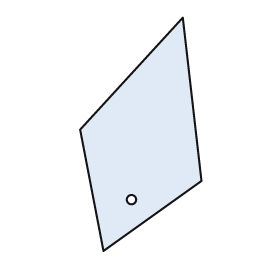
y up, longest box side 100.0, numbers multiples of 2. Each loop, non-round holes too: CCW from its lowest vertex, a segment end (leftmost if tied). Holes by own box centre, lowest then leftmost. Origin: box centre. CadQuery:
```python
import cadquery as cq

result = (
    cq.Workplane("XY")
    .moveTo(-16.0, -50.0)
    .lineTo(26.0, -20.0)
    .lineTo(18.0, 50.0)
    .lineTo(-26.0, 2.0)
    .close()
    .moveTo(-4.0, -28.0)
    .circle(2.0)
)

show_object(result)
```